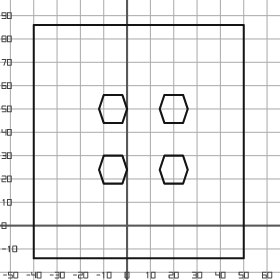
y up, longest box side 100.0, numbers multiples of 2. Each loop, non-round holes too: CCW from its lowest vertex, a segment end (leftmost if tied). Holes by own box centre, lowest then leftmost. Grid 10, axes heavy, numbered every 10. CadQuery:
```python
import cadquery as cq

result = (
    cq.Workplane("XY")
    .moveTo(-40.0, -14.0)
    .lineTo(50.0, -14.0)
    .lineTo(50.0, 86.0)
    .lineTo(-40.0, 86.0)
    .close()
    .moveTo(-10.0, 18.0)
    .lineTo(-2.0, 18.0)
    .lineTo(0.0, 24.0)
    .lineTo(-2.0, 30.0)
    .lineTo(-10.0, 30.0)
    .lineTo(-12.0, 24.0)
    .close()
    .moveTo(16.0, 18.0)
    .lineTo(24.0, 18.0)
    .lineTo(26.0, 24.0)
    .lineTo(24.0, 30.0)
    .lineTo(16.0, 30.0)
    .lineTo(14.0, 24.0)
    .close()
    .moveTo(-10.0, 44.0)
    .lineTo(-2.0, 44.0)
    .lineTo(0.0, 50.0)
    .lineTo(-2.0, 56.0)
    .lineTo(-10.0, 56.0)
    .lineTo(-12.0, 50.0)
    .close()
    .moveTo(16.0, 44.0)
    .lineTo(24.0, 44.0)
    .lineTo(26.0, 50.0)
    .lineTo(24.0, 56.0)
    .lineTo(16.0, 56.0)
    .lineTo(14.0, 50.0)
    .close()
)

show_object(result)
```